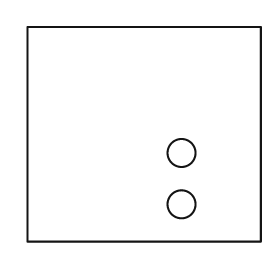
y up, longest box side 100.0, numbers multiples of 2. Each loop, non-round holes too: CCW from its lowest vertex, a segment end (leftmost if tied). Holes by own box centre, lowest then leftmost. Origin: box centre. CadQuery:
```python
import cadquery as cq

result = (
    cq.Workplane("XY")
    .moveTo(-50.0, -46.0)
    .lineTo(50.0, -46.0)
    .lineTo(50.0, 46.0)
    .lineTo(-50.0, 46.0)
    .close()
    .moveTo(16.0, -30.0)
    .circle(6.0)
    .moveTo(16.0, -8.0)
    .circle(6.0)
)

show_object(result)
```